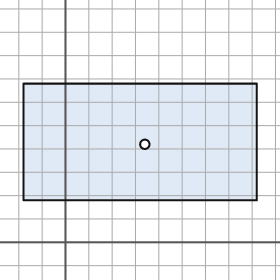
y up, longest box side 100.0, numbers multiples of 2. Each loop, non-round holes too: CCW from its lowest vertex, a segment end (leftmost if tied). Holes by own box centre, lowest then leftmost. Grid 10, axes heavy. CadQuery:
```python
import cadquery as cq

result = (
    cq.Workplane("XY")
    .moveTo(-18.0, 18.0)
    .lineTo(82.0, 18.0)
    .lineTo(82.0, 68.0)
    .lineTo(-18.0, 68.0)
    .close()
    .moveTo(34.0, 42.0)
    .circle(2.0)
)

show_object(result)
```